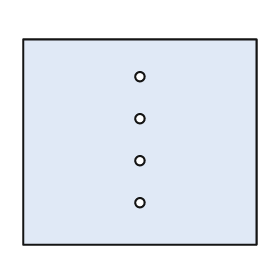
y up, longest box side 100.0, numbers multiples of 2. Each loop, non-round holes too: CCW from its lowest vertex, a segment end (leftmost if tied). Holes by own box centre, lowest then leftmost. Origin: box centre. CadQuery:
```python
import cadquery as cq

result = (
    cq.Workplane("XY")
    .moveTo(-50.0, -44.0)
    .lineTo(50.0, -44.0)
    .lineTo(50.0, 44.0)
    .lineTo(-50.0, 44.0)
    .close()
    .moveTo(0.0, -26.0)
    .circle(2.0)
    .moveTo(0.0, -8.0)
    .circle(2.0)
    .moveTo(0.0, 10.0)
    .circle(2.0)
    .moveTo(0.0, 28.0)
    .circle(2.0)
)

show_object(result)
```